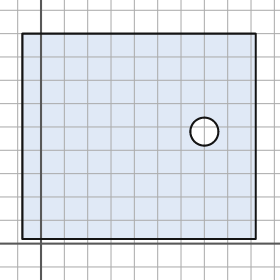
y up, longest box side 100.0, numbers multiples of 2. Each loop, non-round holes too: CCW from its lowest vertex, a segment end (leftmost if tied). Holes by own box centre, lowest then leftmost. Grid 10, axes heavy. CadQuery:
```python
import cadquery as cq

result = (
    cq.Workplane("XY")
    .moveTo(-8.0, 2.0)
    .lineTo(92.0, 2.0)
    .lineTo(92.0, 90.0)
    .lineTo(-8.0, 90.0)
    .close()
    .moveTo(70.0, 48.0)
    .circle(6.0)
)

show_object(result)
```